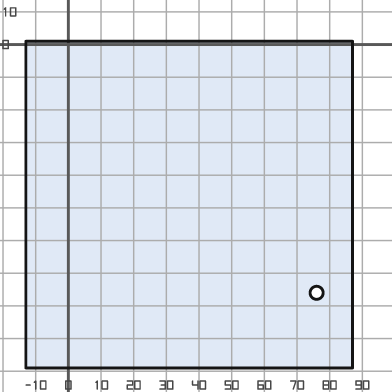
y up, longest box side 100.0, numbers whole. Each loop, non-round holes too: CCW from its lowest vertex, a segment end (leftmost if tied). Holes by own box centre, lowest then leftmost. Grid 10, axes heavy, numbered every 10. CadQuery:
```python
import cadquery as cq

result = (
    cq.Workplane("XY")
    .moveTo(-13.0, -99.0)
    .lineTo(87.0, -99.0)
    .lineTo(87.0, 1.0)
    .lineTo(-13.0, 1.0)
    .close()
    .moveTo(76.0, -76.0)
    .circle(2.0)
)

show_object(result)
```